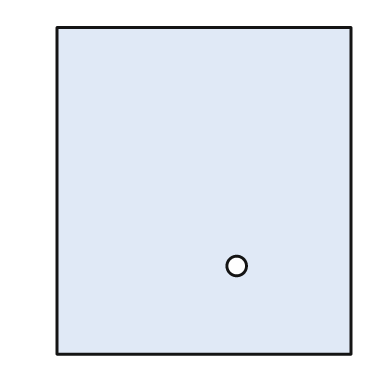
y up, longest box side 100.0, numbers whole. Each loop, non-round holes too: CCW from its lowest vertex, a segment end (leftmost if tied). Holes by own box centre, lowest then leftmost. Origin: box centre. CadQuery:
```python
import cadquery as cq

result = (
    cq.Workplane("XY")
    .moveTo(-45.0, -50.0)
    .lineTo(45.0, -50.0)
    .lineTo(45.0, 50.0)
    .lineTo(-45.0, 50.0)
    .close()
    .moveTo(10.0, -23.0)
    .circle(3.0)
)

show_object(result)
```